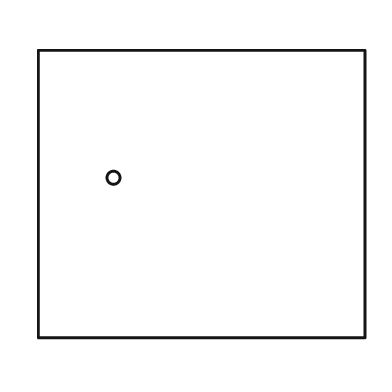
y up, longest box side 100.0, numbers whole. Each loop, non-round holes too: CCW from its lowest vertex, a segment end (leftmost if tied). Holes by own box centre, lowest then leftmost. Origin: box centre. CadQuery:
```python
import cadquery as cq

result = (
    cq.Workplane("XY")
    .moveTo(-50.0, -44.0)
    .lineTo(50.0, -44.0)
    .lineTo(50.0, 44.0)
    .lineTo(-50.0, 44.0)
    .close()
    .moveTo(-27.0, 5.0)
    .circle(2.0)
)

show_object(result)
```